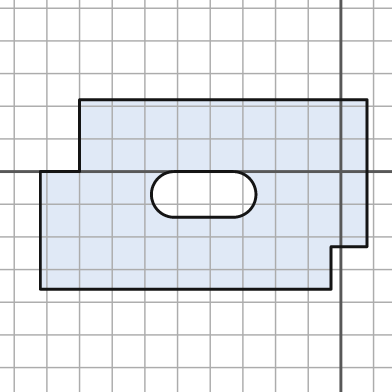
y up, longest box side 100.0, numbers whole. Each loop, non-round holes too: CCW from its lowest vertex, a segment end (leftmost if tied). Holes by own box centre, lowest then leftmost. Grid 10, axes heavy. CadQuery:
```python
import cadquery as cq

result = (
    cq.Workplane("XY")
    .moveTo(-92.0, -36.0)
    .lineTo(-3.0, -36.0)
    .lineTo(-3.0, -23.0)
    .lineTo(8.0, -23.0)
    .lineTo(8.0, 22.0)
    .lineTo(-80.0, 22.0)
    .lineTo(-80.0, 0.0)
    .lineTo(-92.0, 0.0)
    .close()
    .moveTo(-51.0, -14.0)
    .lineTo(-33.0, -14.0)
    .threePointArc((-26.0, -7.0), (-33.0, 0.0))
    .lineTo(-51.0, 0.0)
    .threePointArc((-58.0, -7.0), (-51.0, -14.0))
    .close()
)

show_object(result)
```